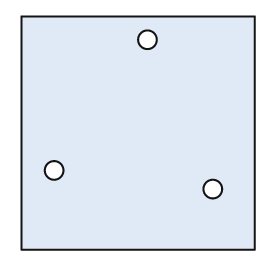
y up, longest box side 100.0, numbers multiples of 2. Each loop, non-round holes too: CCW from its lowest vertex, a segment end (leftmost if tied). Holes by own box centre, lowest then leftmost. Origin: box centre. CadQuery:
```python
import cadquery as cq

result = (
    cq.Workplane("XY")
    .moveTo(-50.0, -50.0)
    .lineTo(50.0, -50.0)
    .lineTo(50.0, 50.0)
    .lineTo(-50.0, 50.0)
    .close()
    .moveTo(32.0, -24.0)
    .circle(4.0)
    .moveTo(-36.0, -16.0)
    .circle(4.0)
    .moveTo(4.0, 40.0)
    .circle(4.0)
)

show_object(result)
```